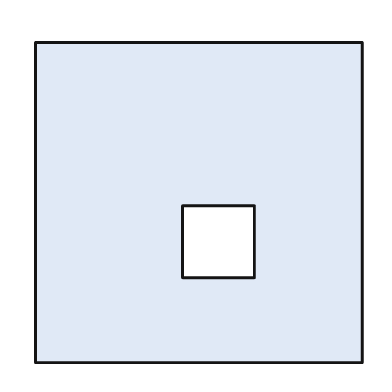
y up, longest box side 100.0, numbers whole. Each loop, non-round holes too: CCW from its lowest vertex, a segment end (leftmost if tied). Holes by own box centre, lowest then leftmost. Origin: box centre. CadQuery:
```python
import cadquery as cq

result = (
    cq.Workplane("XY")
    .moveTo(-50.0, -49.0)
    .lineTo(50.0, -49.0)
    .lineTo(50.0, 49.0)
    .lineTo(-50.0, 49.0)
    .close()
    .moveTo(-5.0, -23.0)
    .lineTo(17.0, -23.0)
    .lineTo(17.0, -1.0)
    .lineTo(-5.0, -1.0)
    .close()
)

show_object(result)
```